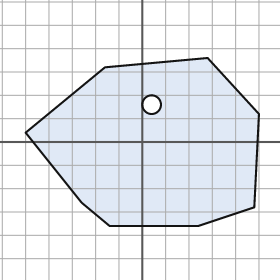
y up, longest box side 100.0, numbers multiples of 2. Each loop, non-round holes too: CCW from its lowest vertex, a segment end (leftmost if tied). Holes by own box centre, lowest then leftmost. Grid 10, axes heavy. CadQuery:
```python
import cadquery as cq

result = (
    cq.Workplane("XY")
    .moveTo(-14.0, -36.0)
    .lineTo(24.0, -36.0)
    .lineTo(48.0, -28.0)
    .lineTo(50.0, 12.0)
    .lineTo(28.0, 36.0)
    .lineTo(-16.0, 32.0)
    .lineTo(-50.0, 4.0)
    .lineTo(-26.0, -26.0)
    .close()
    .moveTo(4.0, 16.0)
    .circle(4.0)
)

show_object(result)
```